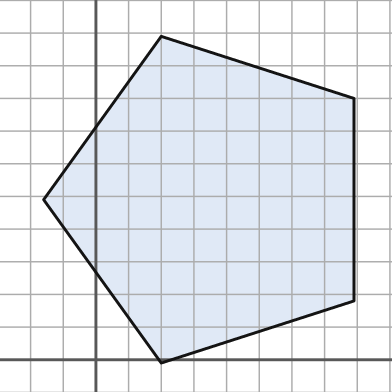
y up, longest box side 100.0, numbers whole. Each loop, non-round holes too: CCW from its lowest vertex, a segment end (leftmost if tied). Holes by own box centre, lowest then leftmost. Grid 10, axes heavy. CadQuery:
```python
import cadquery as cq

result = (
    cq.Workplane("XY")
    .moveTo(20.0, -1.0)
    .lineTo(79.0, 18.0)
    .lineTo(79.0, 80.0)
    .lineTo(20.0, 99.0)
    .lineTo(-16.0, 49.0)
    .close()
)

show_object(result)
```